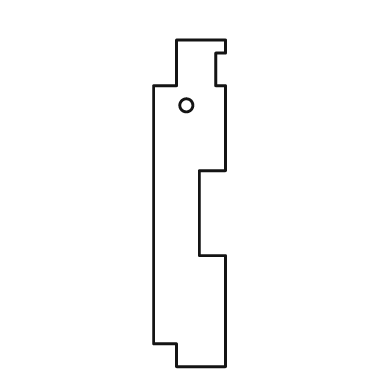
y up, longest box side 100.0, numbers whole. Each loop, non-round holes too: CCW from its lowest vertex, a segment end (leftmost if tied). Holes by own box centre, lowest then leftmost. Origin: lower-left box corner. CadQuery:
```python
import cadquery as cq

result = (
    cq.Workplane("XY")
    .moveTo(7.0, 0.0)
    .lineTo(22.0, 0.0)
    .lineTo(22.0, 34.0)
    .lineTo(14.0, 34.0)
    .lineTo(14.0, 60.0)
    .lineTo(22.0, 60.0)
    .lineTo(22.0, 86.0)
    .lineTo(19.0, 86.0)
    .lineTo(19.0, 96.0)
    .lineTo(22.0, 96.0)
    .lineTo(22.0, 100.0)
    .lineTo(7.0, 100.0)
    .lineTo(7.0, 86.0)
    .lineTo(0.0, 86.0)
    .lineTo(0.0, 7.0)
    .lineTo(7.0, 7.0)
    .close()
    .moveTo(10.0, 80.0)
    .circle(2.0)
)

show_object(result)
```